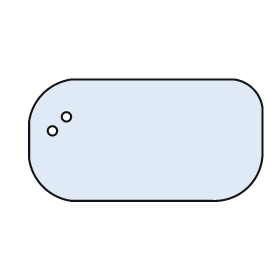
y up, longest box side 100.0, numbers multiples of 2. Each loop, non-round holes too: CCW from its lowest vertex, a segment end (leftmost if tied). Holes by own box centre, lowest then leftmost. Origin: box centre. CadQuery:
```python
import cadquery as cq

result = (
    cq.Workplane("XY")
    .moveTo(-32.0, -26.0)
    .lineTo(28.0, -26.0)
    .threePointArc((44.0, -20.0), (50.0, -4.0))
    .lineTo(50.0, 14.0)
    .threePointArc((46.0, 22.0), (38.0, 26.0))
    .lineTo(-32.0, 26.0)
    .threePointArc((-44.0, 20.0), (-50.0, 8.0))
    .lineTo(-50.0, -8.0)
    .threePointArc((-44.0, -20.0), (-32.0, -26.0))
    .close()
    .moveTo(-40.0, 4.0)
    .circle(2.0)
    .moveTo(-34.0, 10.0)
    .circle(2.0)
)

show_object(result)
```